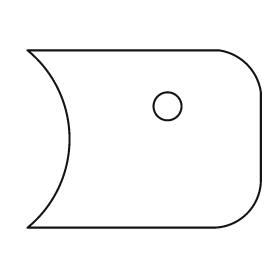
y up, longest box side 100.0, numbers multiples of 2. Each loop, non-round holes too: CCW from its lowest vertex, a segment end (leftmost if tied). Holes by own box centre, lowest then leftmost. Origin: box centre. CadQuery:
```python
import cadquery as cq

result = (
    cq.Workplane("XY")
    .moveTo(-50.0, -38.0)
    .lineTo(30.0, -38.0)
    .threePointArc((44.0, -32.0), (50.0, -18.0))
    .lineTo(50.0, 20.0)
    .threePointArc((44.0, 32.0), (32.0, 38.0))
    .lineTo(-50.0, 38.0)
    .threePointArc((-32.0, 0.0), (-50.0, -38.0))
    .close()
    .moveTo(10.0, 14.0)
    .circle(6.0)
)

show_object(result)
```